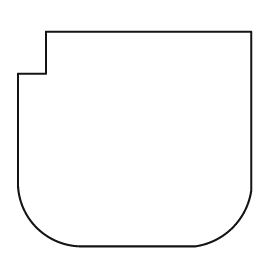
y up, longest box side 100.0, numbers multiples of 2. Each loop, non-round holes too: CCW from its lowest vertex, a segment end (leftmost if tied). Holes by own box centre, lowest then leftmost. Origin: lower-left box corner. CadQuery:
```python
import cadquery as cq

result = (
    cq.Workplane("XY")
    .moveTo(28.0, 0.0)
    .lineTo(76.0, 0.0)
    .threePointArc((92.0, 8.0), (100.0, 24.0))
    .lineTo(100.0, 92.0)
    .lineTo(12.0, 92.0)
    .lineTo(12.0, 74.0)
    .lineTo(0.0, 74.0)
    .lineTo(0.0, 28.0)
    .threePointArc((8.0, 8.0), (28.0, 0.0))
    .close()
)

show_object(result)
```